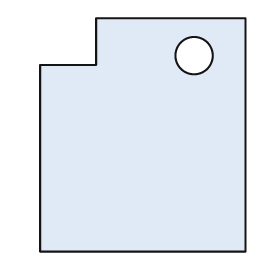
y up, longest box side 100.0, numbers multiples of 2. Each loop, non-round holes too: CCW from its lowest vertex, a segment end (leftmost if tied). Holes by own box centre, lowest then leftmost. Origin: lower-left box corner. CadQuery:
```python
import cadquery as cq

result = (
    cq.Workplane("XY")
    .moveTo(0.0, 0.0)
    .lineTo(88.0, 0.0)
    .lineTo(88.0, 100.0)
    .lineTo(24.0, 100.0)
    .lineTo(24.0, 80.0)
    .lineTo(0.0, 80.0)
    .close()
    .moveTo(66.0, 84.0)
    .circle(8.0)
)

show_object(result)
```